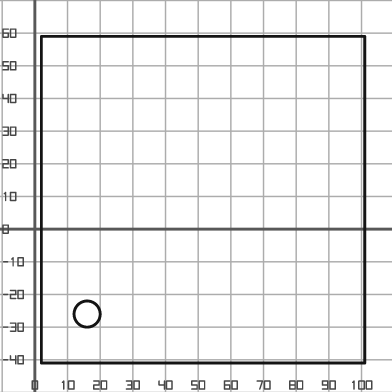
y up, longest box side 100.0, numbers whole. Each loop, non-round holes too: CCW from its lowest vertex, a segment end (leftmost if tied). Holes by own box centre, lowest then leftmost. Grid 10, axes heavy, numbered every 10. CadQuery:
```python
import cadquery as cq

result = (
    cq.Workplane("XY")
    .moveTo(2.0, -41.0)
    .lineTo(101.0, -41.0)
    .lineTo(101.0, 59.0)
    .lineTo(2.0, 59.0)
    .close()
    .moveTo(16.0, -26.0)
    .circle(4.0)
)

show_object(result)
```